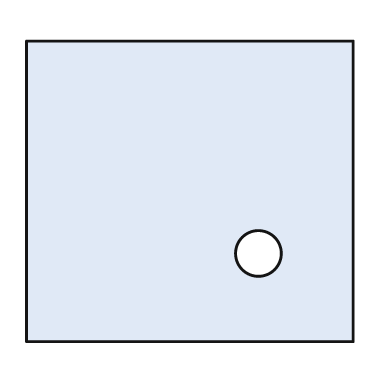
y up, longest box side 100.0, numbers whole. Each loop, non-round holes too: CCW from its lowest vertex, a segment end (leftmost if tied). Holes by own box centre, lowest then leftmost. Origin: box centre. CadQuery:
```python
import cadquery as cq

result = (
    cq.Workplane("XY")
    .moveTo(-50.0, -46.0)
    .lineTo(50.0, -46.0)
    .lineTo(50.0, 46.0)
    .lineTo(-50.0, 46.0)
    .close()
    .moveTo(21.0, -19.0)
    .circle(7.0)
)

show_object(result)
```